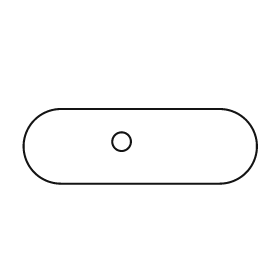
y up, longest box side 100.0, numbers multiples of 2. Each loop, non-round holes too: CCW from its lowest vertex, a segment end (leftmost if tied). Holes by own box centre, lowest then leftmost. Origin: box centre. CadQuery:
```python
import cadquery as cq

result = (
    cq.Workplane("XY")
    .moveTo(-34.0, -16.0)
    .lineTo(34.0, -16.0)
    .threePointArc((50.0, 0.0), (34.0, 16.0))
    .lineTo(-34.0, 16.0)
    .threePointArc((-50.0, 0.0), (-34.0, -16.0))
    .close()
    .moveTo(-8.0, 2.0)
    .circle(4.0)
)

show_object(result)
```